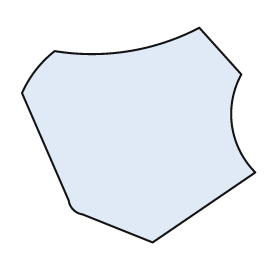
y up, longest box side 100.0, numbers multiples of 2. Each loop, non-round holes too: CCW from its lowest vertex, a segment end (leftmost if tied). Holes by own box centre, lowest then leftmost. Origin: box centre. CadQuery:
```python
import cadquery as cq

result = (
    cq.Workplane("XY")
    .moveTo(6.0, -46.0)
    .lineTo(50.0, -16.0)
    .threePointArc((40.0, 4.0), (44.0, 26.0))
    .lineTo(26.0, 46.0)
    .threePointArc((-4.0, 36.0), (-36.0, 36.0))
    .threePointArc((-44.0, 28.0), (-50.0, 18.0))
    .lineTo(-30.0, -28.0)
    .threePointArc((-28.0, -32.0), (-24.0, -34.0))
    .close()
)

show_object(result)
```